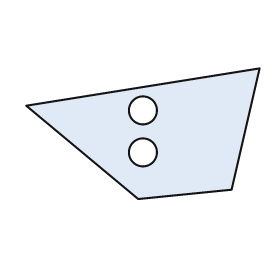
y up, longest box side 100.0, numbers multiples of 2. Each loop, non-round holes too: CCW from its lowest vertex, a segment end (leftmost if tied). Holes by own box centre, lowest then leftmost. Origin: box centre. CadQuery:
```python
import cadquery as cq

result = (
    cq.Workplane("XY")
    .moveTo(-2.0, -28.0)
    .lineTo(38.0, -24.0)
    .lineTo(50.0, 28.0)
    .lineTo(-50.0, 12.0)
    .close()
    .moveTo(0.0, -8.0)
    .circle(6.0)
    .moveTo(0.0, 10.0)
    .circle(6.0)
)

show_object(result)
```